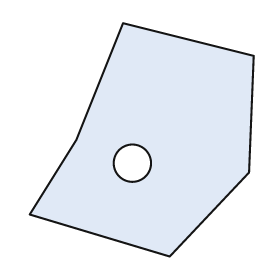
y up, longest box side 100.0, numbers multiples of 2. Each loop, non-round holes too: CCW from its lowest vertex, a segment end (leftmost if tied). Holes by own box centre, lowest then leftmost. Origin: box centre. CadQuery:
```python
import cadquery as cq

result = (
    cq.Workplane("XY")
    .moveTo(12.0, -50.0)
    .lineTo(46.0, -14.0)
    .lineTo(48.0, 36.0)
    .lineTo(-8.0, 50.0)
    .lineTo(-28.0, 0.0)
    .lineTo(-48.0, -32.0)
    .close()
    .moveTo(-4.0, -10.0)
    .circle(8.0)
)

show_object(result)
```